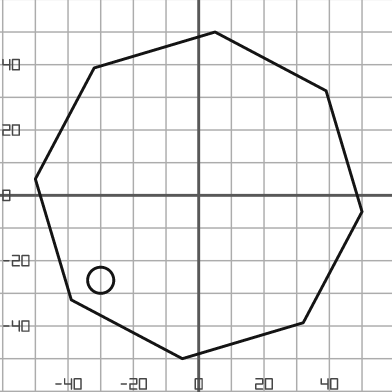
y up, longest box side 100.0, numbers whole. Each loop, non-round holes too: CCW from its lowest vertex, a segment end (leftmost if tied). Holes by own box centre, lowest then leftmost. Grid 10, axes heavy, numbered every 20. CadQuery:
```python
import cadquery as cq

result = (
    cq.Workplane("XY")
    .moveTo(-5.0, -50.0)
    .lineTo(32.0, -39.0)
    .lineTo(50.0, -5.0)
    .lineTo(39.0, 32.0)
    .lineTo(5.0, 50.0)
    .lineTo(-32.0, 39.0)
    .lineTo(-50.0, 5.0)
    .lineTo(-39.0, -32.0)
    .close()
    .moveTo(-30.0, -26.0)
    .circle(4.0)
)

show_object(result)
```